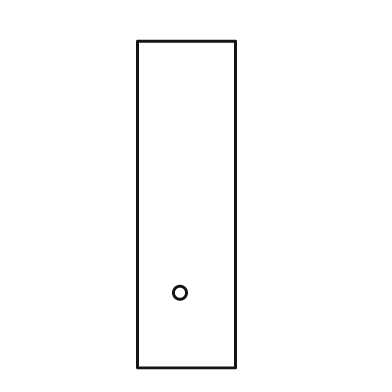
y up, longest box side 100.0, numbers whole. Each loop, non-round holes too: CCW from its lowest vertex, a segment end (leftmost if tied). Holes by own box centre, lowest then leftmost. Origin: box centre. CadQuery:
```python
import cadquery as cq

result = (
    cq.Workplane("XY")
    .moveTo(-15.0, -50.0)
    .lineTo(15.0, -50.0)
    .lineTo(15.0, 50.0)
    .lineTo(-15.0, 50.0)
    .close()
    .moveTo(-2.0, -27.0)
    .circle(2.0)
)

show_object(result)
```